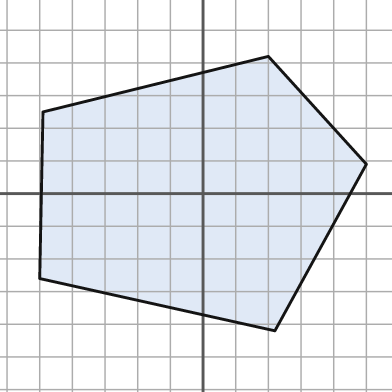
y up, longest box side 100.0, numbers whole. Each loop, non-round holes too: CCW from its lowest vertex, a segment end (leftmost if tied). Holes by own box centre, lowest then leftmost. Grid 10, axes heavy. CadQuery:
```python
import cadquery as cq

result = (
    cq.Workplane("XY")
    .moveTo(22.0, -42.0)
    .lineTo(50.0, 9.0)
    .lineTo(20.0, 42.0)
    .lineTo(-49.0, 25.0)
    .lineTo(-50.0, -26.0)
    .close()
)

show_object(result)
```